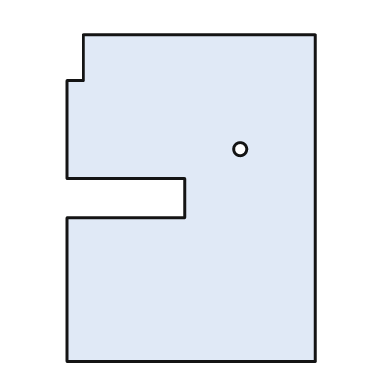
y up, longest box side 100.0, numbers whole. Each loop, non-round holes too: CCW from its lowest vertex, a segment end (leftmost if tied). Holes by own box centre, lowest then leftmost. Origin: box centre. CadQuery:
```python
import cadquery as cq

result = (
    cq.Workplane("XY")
    .moveTo(-38.0, -50.0)
    .lineTo(38.0, -50.0)
    .lineTo(38.0, 50.0)
    .lineTo(-33.0, 50.0)
    .lineTo(-33.0, 36.0)
    .lineTo(-38.0, 36.0)
    .lineTo(-38.0, 6.0)
    .lineTo(-2.0, 6.0)
    .lineTo(-2.0, -6.0)
    .lineTo(-38.0, -6.0)
    .close()
    .moveTo(15.0, 15.0)
    .circle(2.0)
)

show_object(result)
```